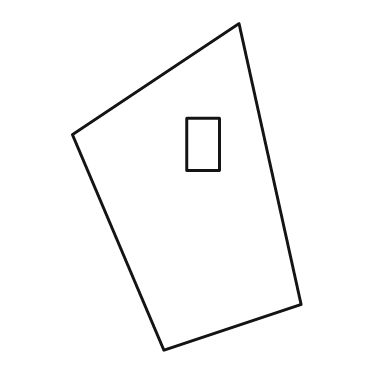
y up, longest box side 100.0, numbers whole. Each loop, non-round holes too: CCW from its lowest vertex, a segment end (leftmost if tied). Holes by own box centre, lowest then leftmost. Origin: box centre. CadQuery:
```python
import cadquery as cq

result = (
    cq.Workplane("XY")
    .moveTo(-7.0, -50.0)
    .lineTo(35.0, -36.0)
    .lineTo(16.0, 50.0)
    .lineTo(-35.0, 16.0)
    .close()
    .moveTo(0.0, 5.0)
    .lineTo(10.0, 5.0)
    .lineTo(10.0, 21.0)
    .lineTo(0.0, 21.0)
    .close()
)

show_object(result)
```